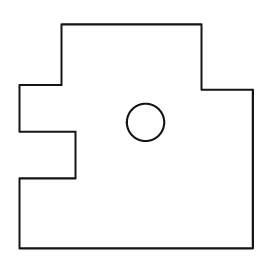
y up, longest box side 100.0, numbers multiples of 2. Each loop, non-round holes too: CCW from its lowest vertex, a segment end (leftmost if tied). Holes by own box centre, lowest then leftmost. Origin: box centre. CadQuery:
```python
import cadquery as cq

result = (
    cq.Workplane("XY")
    .moveTo(-50.0, -48.0)
    .lineTo(50.0, -48.0)
    .lineTo(50.0, 20.0)
    .lineTo(28.0, 20.0)
    .lineTo(28.0, 48.0)
    .lineTo(-32.0, 48.0)
    .lineTo(-32.0, 22.0)
    .lineTo(-50.0, 22.0)
    .lineTo(-50.0, 2.0)
    .lineTo(-26.0, 2.0)
    .lineTo(-26.0, -18.0)
    .lineTo(-50.0, -18.0)
    .close()
    .moveTo(4.0, 6.0)
    .circle(8.0)
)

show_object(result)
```